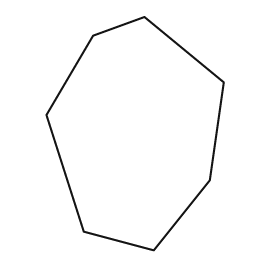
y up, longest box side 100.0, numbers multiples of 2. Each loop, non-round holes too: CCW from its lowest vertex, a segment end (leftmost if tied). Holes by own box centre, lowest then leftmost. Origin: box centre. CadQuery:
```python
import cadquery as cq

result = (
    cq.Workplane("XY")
    .moveTo(8.0, -50.0)
    .lineTo(32.0, -20.0)
    .lineTo(38.0, 22.0)
    .lineTo(4.0, 50.0)
    .lineTo(-18.0, 42.0)
    .lineTo(-38.0, 8.0)
    .lineTo(-22.0, -42.0)
    .close()
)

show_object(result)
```